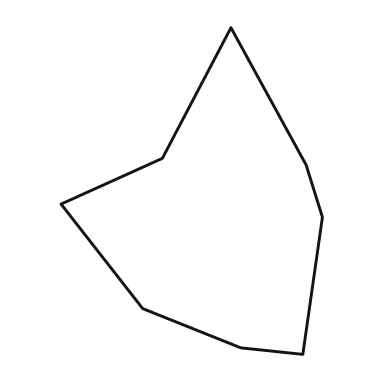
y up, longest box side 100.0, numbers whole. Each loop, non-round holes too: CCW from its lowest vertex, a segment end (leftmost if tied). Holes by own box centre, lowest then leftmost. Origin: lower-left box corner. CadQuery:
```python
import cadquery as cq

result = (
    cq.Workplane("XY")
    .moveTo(74.0, 0.0)
    .lineTo(80.0, 42.0)
    .lineTo(75.0, 58.0)
    .lineTo(52.0, 100.0)
    .lineTo(31.0, 60.0)
    .lineTo(0.0, 46.0)
    .lineTo(25.0, 14.0)
    .lineTo(55.0, 2.0)
    .close()
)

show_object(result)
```